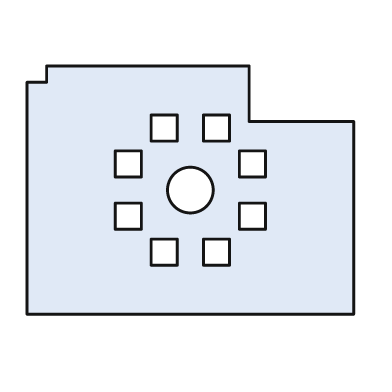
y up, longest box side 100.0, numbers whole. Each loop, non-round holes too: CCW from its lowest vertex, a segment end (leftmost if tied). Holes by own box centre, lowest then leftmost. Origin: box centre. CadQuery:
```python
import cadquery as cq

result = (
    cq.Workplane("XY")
    .moveTo(-50.0, -38.0)
    .lineTo(50.0, -38.0)
    .lineTo(50.0, 21.0)
    .lineTo(18.0, 21.0)
    .lineTo(18.0, 38.0)
    .lineTo(-44.0, 38.0)
    .lineTo(-44.0, 33.0)
    .lineTo(-50.0, 33.0)
    .close()
    .moveTo(-12.0, -23.0)
    .lineTo(-4.0, -23.0)
    .lineTo(-4.0, -15.0)
    .lineTo(-12.0, -15.0)
    .close()
    .moveTo(4.0, -23.0)
    .lineTo(12.0, -23.0)
    .lineTo(12.0, -15.0)
    .lineTo(4.0, -15.0)
    .close()
    .moveTo(-23.0, -12.0)
    .lineTo(-15.0, -12.0)
    .lineTo(-15.0, -4.0)
    .lineTo(-23.0, -4.0)
    .close()
    .moveTo(15.0, -12.0)
    .lineTo(23.0, -12.0)
    .lineTo(23.0, -4.0)
    .lineTo(15.0, -4.0)
    .close()
    .moveTo(0.0, 0.0)
    .circle(7.0)
    .moveTo(-23.0, 4.0)
    .lineTo(-15.0, 4.0)
    .lineTo(-15.0, 12.0)
    .lineTo(-23.0, 12.0)
    .close()
    .moveTo(15.0, 4.0)
    .lineTo(23.0, 4.0)
    .lineTo(23.0, 12.0)
    .lineTo(15.0, 12.0)
    .close()
    .moveTo(-12.0, 15.0)
    .lineTo(-4.0, 15.0)
    .lineTo(-4.0, 23.0)
    .lineTo(-12.0, 23.0)
    .close()
    .moveTo(4.0, 15.0)
    .lineTo(12.0, 15.0)
    .lineTo(12.0, 23.0)
    .lineTo(4.0, 23.0)
    .close()
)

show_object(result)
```